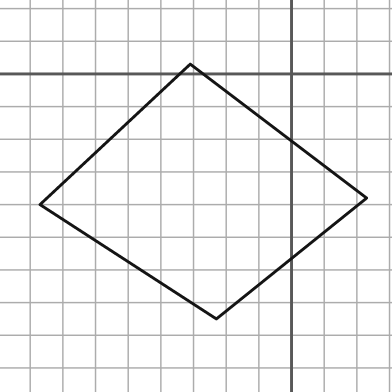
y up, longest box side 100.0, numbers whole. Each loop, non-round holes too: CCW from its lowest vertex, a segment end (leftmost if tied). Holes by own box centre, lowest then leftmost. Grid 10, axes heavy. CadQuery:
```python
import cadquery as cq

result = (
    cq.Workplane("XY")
    .moveTo(-23.0, -75.0)
    .lineTo(23.0, -38.0)
    .lineTo(-31.0, 3.0)
    .lineTo(-77.0, -40.0)
    .close()
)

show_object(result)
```